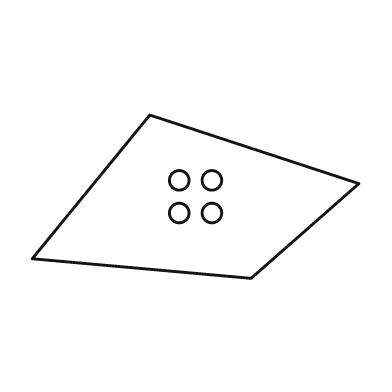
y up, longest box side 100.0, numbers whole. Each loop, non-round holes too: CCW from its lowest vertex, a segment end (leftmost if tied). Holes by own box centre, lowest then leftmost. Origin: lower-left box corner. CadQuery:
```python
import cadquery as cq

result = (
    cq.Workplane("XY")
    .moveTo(67.0, 0.0)
    .lineTo(100.0, 29.0)
    .lineTo(36.0, 50.0)
    .lineTo(0.0, 6.0)
    .close()
    .moveTo(45.0, 20.0)
    .circle(3.0)
    .moveTo(55.0, 20.0)
    .circle(3.0)
    .moveTo(45.0, 30.0)
    .circle(3.0)
    .moveTo(55.0, 30.0)
    .circle(3.0)
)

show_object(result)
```